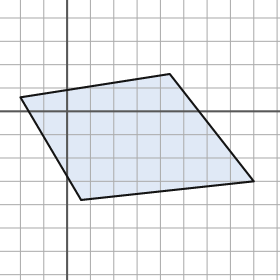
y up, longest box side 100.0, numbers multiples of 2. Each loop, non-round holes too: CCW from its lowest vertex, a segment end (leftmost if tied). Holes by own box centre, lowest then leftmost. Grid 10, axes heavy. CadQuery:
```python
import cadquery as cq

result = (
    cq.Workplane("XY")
    .moveTo(6.0, -38.0)
    .lineTo(80.0, -30.0)
    .lineTo(44.0, 16.0)
    .lineTo(-20.0, 6.0)
    .close()
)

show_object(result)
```